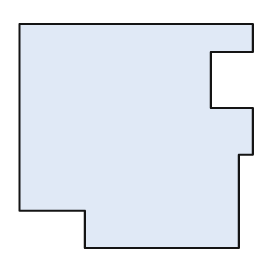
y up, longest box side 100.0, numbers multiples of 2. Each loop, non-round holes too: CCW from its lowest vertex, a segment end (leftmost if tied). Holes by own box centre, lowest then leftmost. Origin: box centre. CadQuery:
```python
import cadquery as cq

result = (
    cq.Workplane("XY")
    .moveTo(-22.0, -48.0)
    .lineTo(44.0, -48.0)
    .lineTo(44.0, -8.0)
    .lineTo(50.0, -8.0)
    .lineTo(50.0, 12.0)
    .lineTo(32.0, 12.0)
    .lineTo(32.0, 36.0)
    .lineTo(50.0, 36.0)
    .lineTo(50.0, 48.0)
    .lineTo(-50.0, 48.0)
    .lineTo(-50.0, -32.0)
    .lineTo(-22.0, -32.0)
    .close()
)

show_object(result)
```